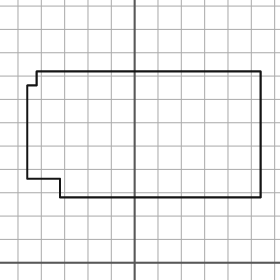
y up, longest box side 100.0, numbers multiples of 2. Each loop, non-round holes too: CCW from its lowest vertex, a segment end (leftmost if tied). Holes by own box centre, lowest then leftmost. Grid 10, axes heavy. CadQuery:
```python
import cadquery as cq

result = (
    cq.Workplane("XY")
    .moveTo(-32.0, 28.0)
    .lineTo(54.0, 28.0)
    .lineTo(54.0, 82.0)
    .lineTo(-42.0, 82.0)
    .lineTo(-42.0, 76.0)
    .lineTo(-46.0, 76.0)
    .lineTo(-46.0, 36.0)
    .lineTo(-32.0, 36.0)
    .close()
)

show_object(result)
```